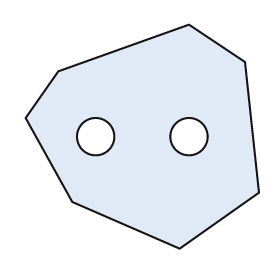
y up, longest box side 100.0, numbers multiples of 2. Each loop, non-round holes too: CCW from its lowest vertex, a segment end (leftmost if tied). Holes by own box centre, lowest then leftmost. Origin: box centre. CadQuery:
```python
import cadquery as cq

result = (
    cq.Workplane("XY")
    .moveTo(16.0, -48.0)
    .lineTo(50.0, -24.0)
    .lineTo(44.0, 32.0)
    .lineTo(20.0, 48.0)
    .lineTo(-36.0, 28.0)
    .lineTo(-50.0, 8.0)
    .lineTo(-30.0, -28.0)
    .close()
    .moveTo(-20.0, 0.0)
    .circle(8.0)
    .moveTo(20.0, 0.0)
    .circle(8.0)
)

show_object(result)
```